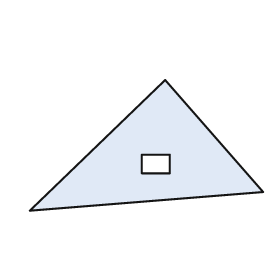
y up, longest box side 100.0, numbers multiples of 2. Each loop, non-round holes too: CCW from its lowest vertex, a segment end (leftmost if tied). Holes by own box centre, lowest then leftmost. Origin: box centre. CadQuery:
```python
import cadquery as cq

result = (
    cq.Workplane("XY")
    .moveTo(-50.0, -28.0)
    .lineTo(50.0, -20.0)
    .lineTo(8.0, 28.0)
    .close()
    .moveTo(-2.0, -12.0)
    .lineTo(10.0, -12.0)
    .lineTo(10.0, -4.0)
    .lineTo(-2.0, -4.0)
    .close()
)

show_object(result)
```